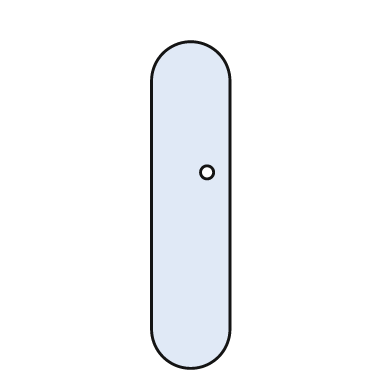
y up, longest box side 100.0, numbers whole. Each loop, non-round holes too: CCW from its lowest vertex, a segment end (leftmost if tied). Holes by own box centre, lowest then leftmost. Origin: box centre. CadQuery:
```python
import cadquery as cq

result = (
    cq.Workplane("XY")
    .moveTo(-12.0, -38.0)
    .threePointArc((0.0, -50.0), (12.0, -38.0))
    .lineTo(12.0, 38.0)
    .threePointArc((0.0, 50.0), (-12.0, 38.0))
    .close()
    .moveTo(5.0, 10.0)
    .circle(2.0)
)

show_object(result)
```